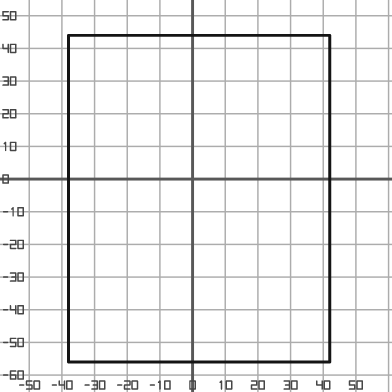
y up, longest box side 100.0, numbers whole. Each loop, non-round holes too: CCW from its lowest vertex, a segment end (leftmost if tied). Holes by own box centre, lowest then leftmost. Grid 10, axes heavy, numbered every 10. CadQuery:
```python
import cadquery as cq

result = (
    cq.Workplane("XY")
    .moveTo(-38.0, -56.0)
    .lineTo(42.0, -56.0)
    .lineTo(42.0, 44.0)
    .lineTo(-38.0, 44.0)
    .close()
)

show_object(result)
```